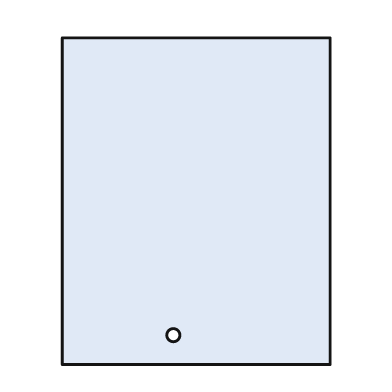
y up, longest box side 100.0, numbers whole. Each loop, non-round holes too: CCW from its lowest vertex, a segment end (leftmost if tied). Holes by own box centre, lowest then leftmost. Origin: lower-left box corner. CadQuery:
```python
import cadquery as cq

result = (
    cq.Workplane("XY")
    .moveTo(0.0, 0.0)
    .lineTo(82.0, 0.0)
    .lineTo(82.0, 100.0)
    .lineTo(0.0, 100.0)
    .close()
    .moveTo(34.0, 9.0)
    .circle(2.0)
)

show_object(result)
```